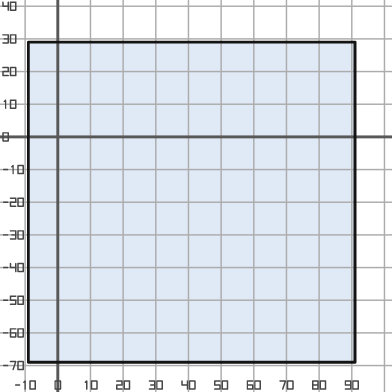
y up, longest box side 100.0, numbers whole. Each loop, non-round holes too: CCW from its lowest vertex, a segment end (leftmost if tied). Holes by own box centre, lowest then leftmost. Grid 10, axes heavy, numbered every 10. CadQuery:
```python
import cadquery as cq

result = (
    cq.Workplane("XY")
    .moveTo(-9.0, -69.0)
    .lineTo(91.0, -69.0)
    .lineTo(91.0, 29.0)
    .lineTo(-9.0, 29.0)
    .close()
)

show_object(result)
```